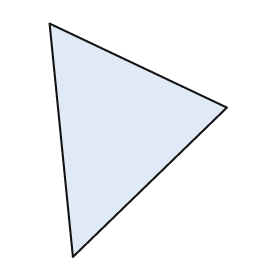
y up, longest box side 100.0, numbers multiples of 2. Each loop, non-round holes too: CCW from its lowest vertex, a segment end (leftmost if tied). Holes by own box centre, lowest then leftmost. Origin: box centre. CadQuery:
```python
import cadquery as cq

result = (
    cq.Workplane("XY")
    .moveTo(-28.0, -50.0)
    .lineTo(38.0, 14.0)
    .lineTo(-38.0, 50.0)
    .close()
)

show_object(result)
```